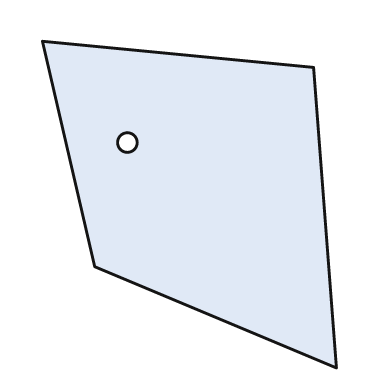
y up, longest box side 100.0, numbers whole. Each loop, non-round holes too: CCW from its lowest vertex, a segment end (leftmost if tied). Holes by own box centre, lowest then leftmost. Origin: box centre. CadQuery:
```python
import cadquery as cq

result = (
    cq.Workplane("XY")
    .moveTo(45.0, -50.0)
    .lineTo(38.0, 42.0)
    .lineTo(-45.0, 50.0)
    .lineTo(-29.0, -19.0)
    .close()
    .moveTo(-19.0, 19.0)
    .circle(3.0)
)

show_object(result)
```